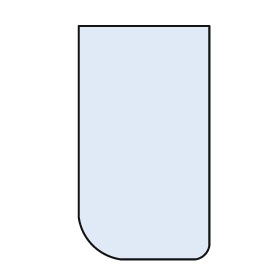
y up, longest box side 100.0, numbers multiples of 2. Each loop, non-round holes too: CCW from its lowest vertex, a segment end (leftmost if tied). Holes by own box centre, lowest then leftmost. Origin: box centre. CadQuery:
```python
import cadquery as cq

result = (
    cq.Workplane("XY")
    .moveTo(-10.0, -50.0)
    .lineTo(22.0, -50.0)
    .threePointArc((26.0, -48.0), (28.0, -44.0))
    .lineTo(28.0, 50.0)
    .lineTo(-28.0, 50.0)
    .lineTo(-28.0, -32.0)
    .threePointArc((-22.0, -44.0), (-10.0, -50.0))
    .close()
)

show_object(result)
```